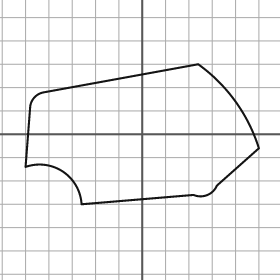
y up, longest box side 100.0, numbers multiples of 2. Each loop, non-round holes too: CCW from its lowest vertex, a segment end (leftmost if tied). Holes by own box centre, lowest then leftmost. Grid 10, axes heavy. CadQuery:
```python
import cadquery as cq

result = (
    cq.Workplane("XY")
    .moveTo(-26.0, -30.0)
    .lineTo(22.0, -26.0)
    .threePointArc((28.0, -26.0), (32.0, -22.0))
    .lineTo(50.0, -6.0)
    .threePointArc((40.0, 14.0), (24.0, 30.0))
    .lineTo(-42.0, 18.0)
    .threePointArc((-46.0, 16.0), (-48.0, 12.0))
    .lineTo(-50.0, -14.0)
    .threePointArc((-34.0, -16.0), (-26.0, -30.0))
    .close()
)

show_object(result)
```